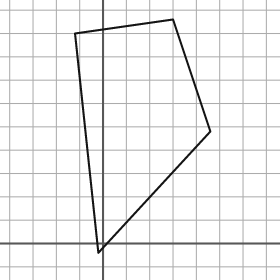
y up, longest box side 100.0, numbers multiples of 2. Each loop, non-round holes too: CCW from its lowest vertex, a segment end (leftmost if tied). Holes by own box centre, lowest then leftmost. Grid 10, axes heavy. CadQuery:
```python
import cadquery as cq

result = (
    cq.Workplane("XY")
    .moveTo(-2.0, -4.0)
    .lineTo(46.0, 48.0)
    .lineTo(30.0, 96.0)
    .lineTo(-12.0, 90.0)
    .close()
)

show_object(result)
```